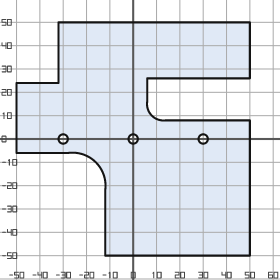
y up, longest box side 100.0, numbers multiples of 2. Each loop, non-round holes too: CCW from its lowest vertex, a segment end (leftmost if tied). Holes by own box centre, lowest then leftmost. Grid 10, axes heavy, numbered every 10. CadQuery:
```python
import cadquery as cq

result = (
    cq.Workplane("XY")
    .moveTo(-12.0, -50.0)
    .lineTo(50.0, -50.0)
    .lineTo(50.0, 8.0)
    .lineTo(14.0, 8.0)
    .threePointArc((8.0, 10.0), (6.0, 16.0))
    .lineTo(6.0, 26.0)
    .lineTo(50.0, 26.0)
    .lineTo(50.0, 50.0)
    .lineTo(-32.0, 50.0)
    .lineTo(-32.0, 24.0)
    .lineTo(-50.0, 24.0)
    .lineTo(-50.0, -6.0)
    .lineTo(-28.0, -6.0)
    .threePointArc((-16.0, -10.0), (-12.0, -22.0))
    .close()
    .moveTo(-30.0, 0.0)
    .circle(2.0)
    .moveTo(0.0, 0.0)
    .circle(2.0)
    .moveTo(30.0, 0.0)
    .circle(2.0)
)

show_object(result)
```